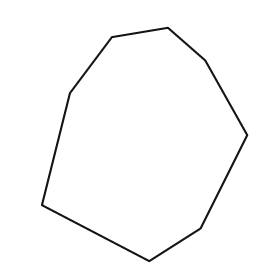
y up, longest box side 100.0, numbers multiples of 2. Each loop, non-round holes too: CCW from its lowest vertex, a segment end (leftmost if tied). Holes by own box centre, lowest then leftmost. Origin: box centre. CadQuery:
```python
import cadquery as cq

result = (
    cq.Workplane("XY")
    .moveTo(2.0, -50.0)
    .lineTo(24.0, -36.0)
    .lineTo(44.0, 4.0)
    .lineTo(26.0, 36.0)
    .lineTo(10.0, 50.0)
    .lineTo(-14.0, 46.0)
    .lineTo(-32.0, 22.0)
    .lineTo(-44.0, -26.0)
    .close()
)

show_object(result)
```